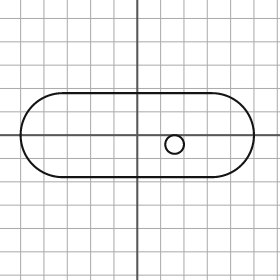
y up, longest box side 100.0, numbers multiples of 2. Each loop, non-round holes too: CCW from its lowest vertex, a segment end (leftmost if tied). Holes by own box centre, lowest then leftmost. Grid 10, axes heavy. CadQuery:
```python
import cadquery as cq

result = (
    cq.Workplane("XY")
    .moveTo(-32.0, -18.0)
    .lineTo(32.0, -18.0)
    .threePointArc((50.0, 0.0), (32.0, 18.0))
    .lineTo(-32.0, 18.0)
    .threePointArc((-50.0, 0.0), (-32.0, -18.0))
    .close()
    .moveTo(16.0, -4.0)
    .circle(4.0)
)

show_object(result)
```